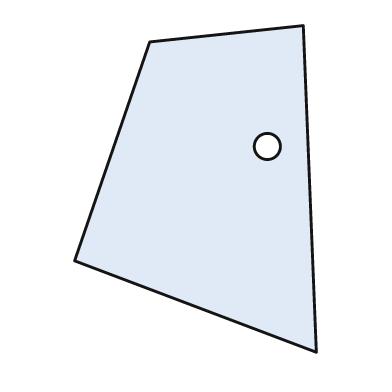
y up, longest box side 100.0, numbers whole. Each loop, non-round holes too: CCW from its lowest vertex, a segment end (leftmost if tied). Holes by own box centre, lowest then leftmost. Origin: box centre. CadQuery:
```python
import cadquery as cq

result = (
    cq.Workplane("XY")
    .moveTo(37.0, -50.0)
    .lineTo(33.0, 50.0)
    .lineTo(-14.0, 45.0)
    .lineTo(-37.0, -22.0)
    .close()
    .moveTo(22.0, 13.0)
    .circle(4.0)
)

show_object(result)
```